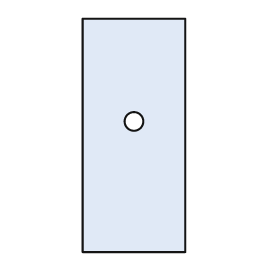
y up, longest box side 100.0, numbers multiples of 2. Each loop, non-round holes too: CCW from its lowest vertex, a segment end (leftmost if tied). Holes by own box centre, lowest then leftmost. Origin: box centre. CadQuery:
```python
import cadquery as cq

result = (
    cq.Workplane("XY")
    .moveTo(-22.0, -50.0)
    .lineTo(22.0, -50.0)
    .lineTo(22.0, 50.0)
    .lineTo(-22.0, 50.0)
    .close()
    .moveTo(0.0, 6.0)
    .circle(4.0)
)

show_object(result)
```